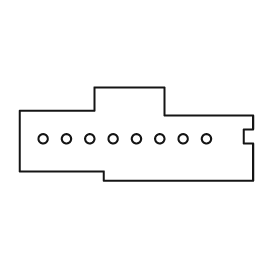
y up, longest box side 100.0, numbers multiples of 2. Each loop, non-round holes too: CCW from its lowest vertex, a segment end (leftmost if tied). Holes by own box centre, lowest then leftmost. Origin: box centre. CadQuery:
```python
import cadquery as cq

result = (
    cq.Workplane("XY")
    .moveTo(-14.0, -20.0)
    .lineTo(50.0, -20.0)
    .lineTo(50.0, -4.0)
    .lineTo(46.0, -4.0)
    .lineTo(46.0, 2.0)
    .lineTo(50.0, 2.0)
    .lineTo(50.0, 8.0)
    .lineTo(12.0, 8.0)
    .lineTo(12.0, 20.0)
    .lineTo(-18.0, 20.0)
    .lineTo(-18.0, 10.0)
    .lineTo(-50.0, 10.0)
    .lineTo(-50.0, -16.0)
    .lineTo(-14.0, -16.0)
    .close()
    .moveTo(-40.0, -2.0)
    .circle(2.0)
    .moveTo(-30.0, -2.0)
    .circle(2.0)
    .moveTo(-20.0, -2.0)
    .circle(2.0)
    .moveTo(-10.0, -2.0)
    .circle(2.0)
    .moveTo(0.0, -2.0)
    .circle(2.0)
    .moveTo(10.0, -2.0)
    .circle(2.0)
    .moveTo(20.0, -2.0)
    .circle(2.0)
    .moveTo(30.0, -2.0)
    .circle(2.0)
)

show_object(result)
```